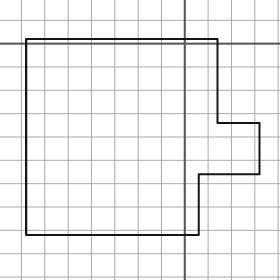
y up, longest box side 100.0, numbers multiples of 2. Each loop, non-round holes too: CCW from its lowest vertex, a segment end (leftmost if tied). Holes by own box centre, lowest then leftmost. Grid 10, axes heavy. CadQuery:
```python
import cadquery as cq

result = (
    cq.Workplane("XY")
    .moveTo(-68.0, -82.0)
    .lineTo(6.0, -82.0)
    .lineTo(6.0, -56.0)
    .lineTo(32.0, -56.0)
    .lineTo(32.0, -34.0)
    .lineTo(14.0, -34.0)
    .lineTo(14.0, 2.0)
    .lineTo(-68.0, 2.0)
    .close()
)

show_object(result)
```